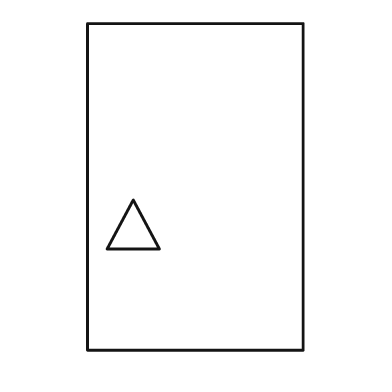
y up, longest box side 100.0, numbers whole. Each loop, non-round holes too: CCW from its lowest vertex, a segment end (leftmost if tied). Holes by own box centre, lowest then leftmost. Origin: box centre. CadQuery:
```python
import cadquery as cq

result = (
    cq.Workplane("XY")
    .moveTo(-33.0, -50.0)
    .lineTo(33.0, -50.0)
    .lineTo(33.0, 50.0)
    .lineTo(-33.0, 50.0)
    .close()
    .moveTo(-27.0, -19.0)
    .lineTo(-11.0, -19.0)
    .lineTo(-19.0, -4.0)
    .close()
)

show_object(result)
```